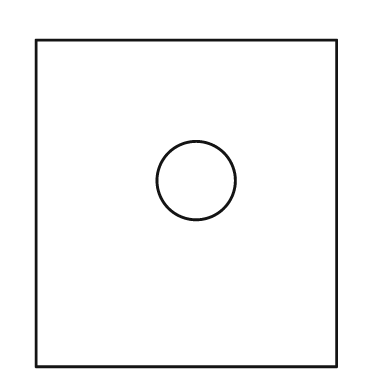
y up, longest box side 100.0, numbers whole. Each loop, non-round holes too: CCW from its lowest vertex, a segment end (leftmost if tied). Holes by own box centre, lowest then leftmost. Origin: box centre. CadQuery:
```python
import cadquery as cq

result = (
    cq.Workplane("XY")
    .moveTo(-46.0, -50.0)
    .lineTo(46.0, -50.0)
    .lineTo(46.0, 50.0)
    .lineTo(-46.0, 50.0)
    .close()
    .moveTo(3.0, 7.0)
    .circle(12.0)
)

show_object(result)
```